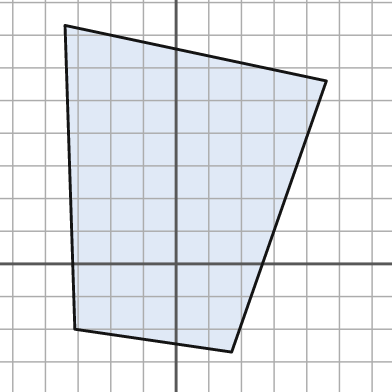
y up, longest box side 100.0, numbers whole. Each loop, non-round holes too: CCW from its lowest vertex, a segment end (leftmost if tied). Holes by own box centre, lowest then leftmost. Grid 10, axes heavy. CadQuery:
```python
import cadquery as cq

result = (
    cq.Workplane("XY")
    .moveTo(17.0, -27.0)
    .lineTo(46.0, 56.0)
    .lineTo(-34.0, 73.0)
    .lineTo(-31.0, -20.0)
    .close()
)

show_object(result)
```